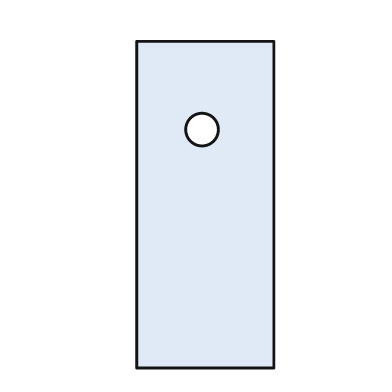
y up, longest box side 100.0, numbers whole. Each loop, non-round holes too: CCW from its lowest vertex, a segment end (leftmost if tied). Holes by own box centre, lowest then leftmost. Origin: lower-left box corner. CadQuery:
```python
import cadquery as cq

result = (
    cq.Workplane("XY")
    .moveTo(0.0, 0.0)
    .lineTo(42.0, 0.0)
    .lineTo(42.0, 100.0)
    .lineTo(0.0, 100.0)
    .close()
    .moveTo(20.0, 73.0)
    .circle(5.0)
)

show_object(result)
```